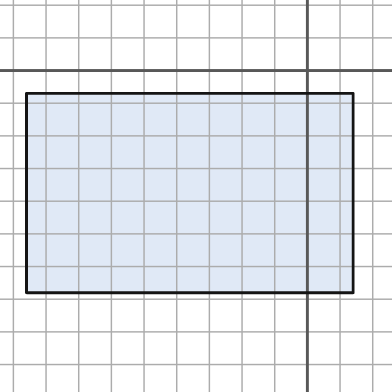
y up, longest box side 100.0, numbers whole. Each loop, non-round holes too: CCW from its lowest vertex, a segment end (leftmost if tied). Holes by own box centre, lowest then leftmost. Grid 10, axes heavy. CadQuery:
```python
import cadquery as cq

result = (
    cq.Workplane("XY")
    .moveTo(-86.0, -68.0)
    .lineTo(14.0, -68.0)
    .lineTo(14.0, -7.0)
    .lineTo(-86.0, -7.0)
    .close()
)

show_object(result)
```